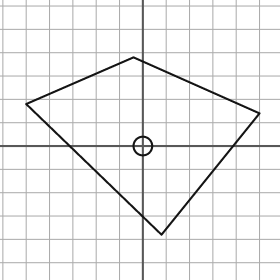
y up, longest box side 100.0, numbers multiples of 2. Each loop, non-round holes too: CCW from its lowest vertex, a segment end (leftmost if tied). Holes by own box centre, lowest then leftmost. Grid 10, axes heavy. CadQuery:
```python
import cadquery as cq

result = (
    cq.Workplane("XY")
    .moveTo(8.0, -38.0)
    .lineTo(50.0, 14.0)
    .lineTo(-4.0, 38.0)
    .lineTo(-50.0, 18.0)
    .close()
    .moveTo(0.0, 0.0)
    .circle(4.0)
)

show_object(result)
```